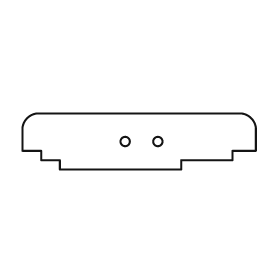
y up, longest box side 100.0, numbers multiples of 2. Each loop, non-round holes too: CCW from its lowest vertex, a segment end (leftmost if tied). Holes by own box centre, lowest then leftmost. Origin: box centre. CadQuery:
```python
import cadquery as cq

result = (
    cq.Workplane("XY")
    .moveTo(-34.0, -12.0)
    .lineTo(18.0, -12.0)
    .lineTo(18.0, -8.0)
    .lineTo(40.0, -8.0)
    .lineTo(40.0, -4.0)
    .lineTo(50.0, -4.0)
    .lineTo(50.0, 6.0)
    .threePointArc((48.0, 10.0), (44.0, 12.0))
    .lineTo(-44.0, 12.0)
    .threePointArc((-48.0, 10.0), (-50.0, 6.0))
    .lineTo(-50.0, -4.0)
    .lineTo(-42.0, -4.0)
    .lineTo(-42.0, -8.0)
    .lineTo(-34.0, -8.0)
    .close()
    .moveTo(-6.0, 0.0)
    .circle(2.0)
    .moveTo(8.0, 0.0)
    .circle(2.0)
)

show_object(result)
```